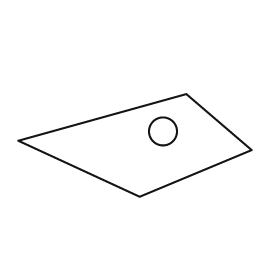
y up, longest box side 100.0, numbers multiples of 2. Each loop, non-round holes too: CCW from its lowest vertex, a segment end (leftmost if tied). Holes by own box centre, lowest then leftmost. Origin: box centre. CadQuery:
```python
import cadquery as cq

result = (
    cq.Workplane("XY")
    .moveTo(2.0, -22.0)
    .lineTo(50.0, -2.0)
    .lineTo(22.0, 22.0)
    .lineTo(-50.0, 2.0)
    .close()
    .moveTo(12.0, 6.0)
    .circle(6.0)
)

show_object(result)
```